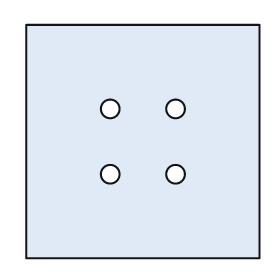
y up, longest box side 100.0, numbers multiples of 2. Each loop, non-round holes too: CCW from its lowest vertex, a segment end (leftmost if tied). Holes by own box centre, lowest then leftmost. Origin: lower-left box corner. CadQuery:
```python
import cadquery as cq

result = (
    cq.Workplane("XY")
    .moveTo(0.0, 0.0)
    .lineTo(100.0, 0.0)
    .lineTo(100.0, 100.0)
    .lineTo(0.0, 100.0)
    .close()
    .moveTo(36.0, 36.0)
    .circle(4.0)
    .moveTo(64.0, 36.0)
    .circle(4.0)
    .moveTo(36.0, 64.0)
    .circle(4.0)
    .moveTo(64.0, 64.0)
    .circle(4.0)
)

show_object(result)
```